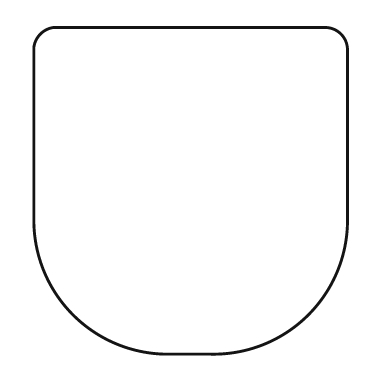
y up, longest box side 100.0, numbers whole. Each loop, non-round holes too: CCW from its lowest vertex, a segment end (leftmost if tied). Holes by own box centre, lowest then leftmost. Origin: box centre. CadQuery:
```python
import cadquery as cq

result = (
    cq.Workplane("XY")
    .moveTo(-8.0, -50.0)
    .lineTo(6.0, -50.0)
    .threePointArc((36.0, -38.0), (48.0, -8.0))
    .lineTo(48.0, 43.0)
    .threePointArc((46.0, 48.0), (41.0, 50.0))
    .lineTo(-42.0, 50.0)
    .threePointArc((-46.0, 48.0), (-48.0, 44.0))
    .lineTo(-48.0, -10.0)
    .threePointArc((-36.0, -38.0), (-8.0, -50.0))
    .close()
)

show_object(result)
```